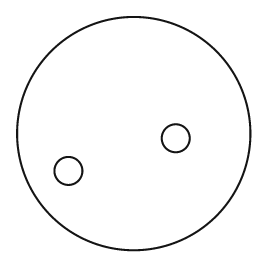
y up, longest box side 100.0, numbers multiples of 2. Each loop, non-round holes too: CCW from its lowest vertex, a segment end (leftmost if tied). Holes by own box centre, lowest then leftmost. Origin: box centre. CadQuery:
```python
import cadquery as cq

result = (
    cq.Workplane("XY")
    .moveTo(0.0, 0.0)
    .circle(50.0)
    .moveTo(-28.0, -16.0)
    .circle(6.0)
    .moveTo(18.0, -2.0)
    .circle(6.0)
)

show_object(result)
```